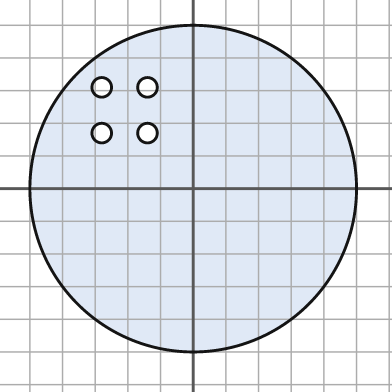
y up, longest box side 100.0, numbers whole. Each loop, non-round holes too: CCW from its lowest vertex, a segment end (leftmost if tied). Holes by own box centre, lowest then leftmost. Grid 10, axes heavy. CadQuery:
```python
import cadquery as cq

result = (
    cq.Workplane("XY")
    .moveTo(0.0, 0.0)
    .circle(50.0)
    .moveTo(-28.0, 17.0)
    .circle(3.0)
    .moveTo(-14.0, 17.0)
    .circle(3.0)
    .moveTo(-28.0, 31.0)
    .circle(3.0)
    .moveTo(-14.0, 31.0)
    .circle(3.0)
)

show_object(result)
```